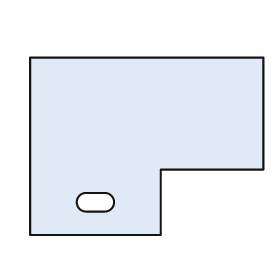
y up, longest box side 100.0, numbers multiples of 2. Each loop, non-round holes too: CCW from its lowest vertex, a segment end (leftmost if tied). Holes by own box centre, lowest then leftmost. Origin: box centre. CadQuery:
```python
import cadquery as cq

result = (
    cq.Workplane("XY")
    .moveTo(-50.0, -38.0)
    .lineTo(6.0, -38.0)
    .lineTo(6.0, -10.0)
    .lineTo(50.0, -10.0)
    .lineTo(50.0, 38.0)
    .lineTo(-50.0, 38.0)
    .close()
    .moveTo(-26.0, -28.0)
    .lineTo(-18.0, -28.0)
    .threePointArc((-14.0, -24.0), (-18.0, -20.0))
    .lineTo(-26.0, -20.0)
    .threePointArc((-30.0, -24.0), (-26.0, -28.0))
    .close()
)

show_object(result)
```